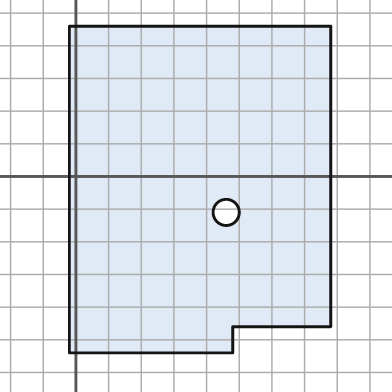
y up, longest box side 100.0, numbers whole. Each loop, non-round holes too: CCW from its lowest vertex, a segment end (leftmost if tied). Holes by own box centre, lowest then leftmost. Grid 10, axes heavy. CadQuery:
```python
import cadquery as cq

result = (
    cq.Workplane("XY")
    .moveTo(-2.0, -54.0)
    .lineTo(48.0, -54.0)
    .lineTo(48.0, -46.0)
    .lineTo(78.0, -46.0)
    .lineTo(78.0, 46.0)
    .lineTo(-2.0, 46.0)
    .close()
    .moveTo(46.0, -11.0)
    .circle(4.0)
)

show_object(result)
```